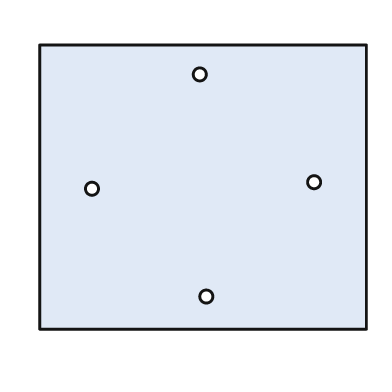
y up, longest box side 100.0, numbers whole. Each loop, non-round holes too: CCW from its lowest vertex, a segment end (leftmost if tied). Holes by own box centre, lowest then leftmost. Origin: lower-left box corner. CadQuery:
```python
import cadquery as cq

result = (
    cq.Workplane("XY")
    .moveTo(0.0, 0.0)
    .lineTo(100.0, 0.0)
    .lineTo(100.0, 87.0)
    .lineTo(0.0, 87.0)
    .close()
    .moveTo(51.0, 10.0)
    .circle(2.0)
    .moveTo(16.0, 43.0)
    .circle(2.0)
    .moveTo(84.0, 45.0)
    .circle(2.0)
    .moveTo(49.0, 78.0)
    .circle(2.0)
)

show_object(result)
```